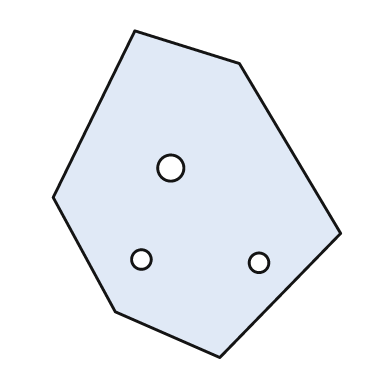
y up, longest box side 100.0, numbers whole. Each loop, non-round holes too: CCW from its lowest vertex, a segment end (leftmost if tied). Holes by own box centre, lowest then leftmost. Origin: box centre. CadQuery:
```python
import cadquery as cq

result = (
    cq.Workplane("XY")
    .moveTo(7.0, -50.0)
    .lineTo(44.0, -12.0)
    .lineTo(13.0, 40.0)
    .lineTo(-19.0, 50.0)
    .lineTo(-44.0, -1.0)
    .lineTo(-25.0, -36.0)
    .close()
    .moveTo(19.0, -21.0)
    .circle(3.0)
    .moveTo(-17.0, -20.0)
    .circle(3.0)
    .moveTo(-8.0, 8.0)
    .circle(4.0)
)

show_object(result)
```